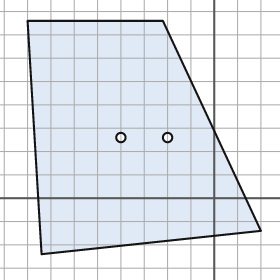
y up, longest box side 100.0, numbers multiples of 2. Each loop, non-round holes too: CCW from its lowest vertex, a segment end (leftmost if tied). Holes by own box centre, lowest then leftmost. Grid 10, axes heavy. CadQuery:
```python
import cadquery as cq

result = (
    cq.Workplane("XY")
    .moveTo(-74.0, -24.0)
    .lineTo(20.0, -14.0)
    .lineTo(-22.0, 76.0)
    .lineTo(-80.0, 76.0)
    .close()
    .moveTo(-40.0, 26.0)
    .circle(2.0)
    .moveTo(-20.0, 26.0)
    .circle(2.0)
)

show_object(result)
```